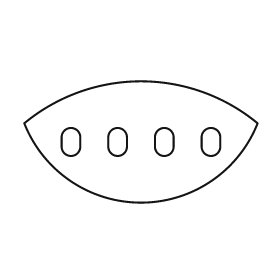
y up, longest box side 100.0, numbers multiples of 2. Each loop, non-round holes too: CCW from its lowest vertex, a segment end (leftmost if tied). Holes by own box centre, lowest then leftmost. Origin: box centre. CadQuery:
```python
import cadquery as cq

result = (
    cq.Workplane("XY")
    .moveTo(-50.0, 8.0)
    .threePointArc((0.0, -26.0), (50.0, 8.0))
    .threePointArc((0.0, 26.0), (-50.0, 8.0))
    .close()
    .moveTo(-34.0, -2.0)
    .threePointArc((-30.0, -6.0), (-26.0, -2.0))
    .lineTo(-26.0, 2.0)
    .threePointArc((-30.0, 6.0), (-34.0, 2.0))
    .close()
    .moveTo(-14.0, -2.0)
    .threePointArc((-10.0, -6.0), (-6.0, -2.0))
    .lineTo(-6.0, 2.0)
    .threePointArc((-10.0, 6.0), (-14.0, 2.0))
    .close()
    .moveTo(6.0, -2.0)
    .threePointArc((10.0, -6.0), (14.0, -2.0))
    .lineTo(14.0, 2.0)
    .threePointArc((10.0, 6.0), (6.0, 2.0))
    .close()
    .moveTo(26.0, -2.0)
    .threePointArc((30.0, -6.0), (34.0, -2.0))
    .lineTo(34.0, 2.0)
    .threePointArc((30.0, 6.0), (26.0, 2.0))
    .close()
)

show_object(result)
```